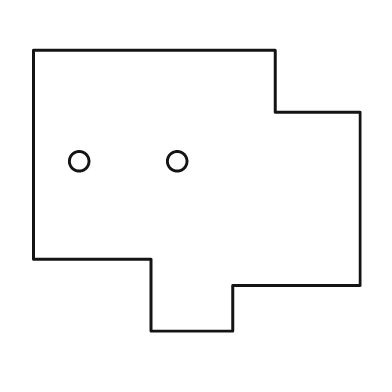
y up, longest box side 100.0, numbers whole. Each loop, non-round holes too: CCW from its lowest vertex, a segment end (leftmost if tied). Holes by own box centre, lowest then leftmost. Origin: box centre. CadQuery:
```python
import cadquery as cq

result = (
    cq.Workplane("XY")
    .moveTo(-14.0, -43.0)
    .lineTo(11.0, -43.0)
    .lineTo(11.0, -29.0)
    .lineTo(50.0, -29.0)
    .lineTo(50.0, 24.0)
    .lineTo(24.0, 24.0)
    .lineTo(24.0, 43.0)
    .lineTo(-50.0, 43.0)
    .lineTo(-50.0, -21.0)
    .lineTo(-14.0, -21.0)
    .close()
    .moveTo(-36.0, 9.0)
    .circle(3.0)
    .moveTo(-6.0, 9.0)
    .circle(3.0)
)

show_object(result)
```